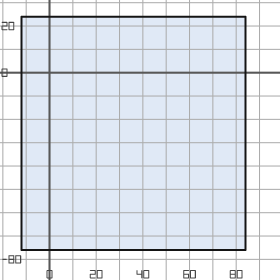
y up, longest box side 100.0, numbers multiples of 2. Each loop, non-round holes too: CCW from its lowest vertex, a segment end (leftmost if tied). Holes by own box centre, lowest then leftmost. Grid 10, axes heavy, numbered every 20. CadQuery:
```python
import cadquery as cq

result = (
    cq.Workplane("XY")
    .moveTo(-12.0, -76.0)
    .lineTo(84.0, -76.0)
    .lineTo(84.0, 24.0)
    .lineTo(-12.0, 24.0)
    .close()
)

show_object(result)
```